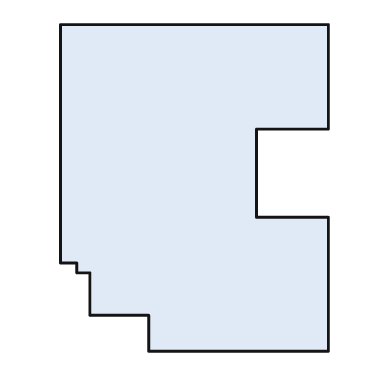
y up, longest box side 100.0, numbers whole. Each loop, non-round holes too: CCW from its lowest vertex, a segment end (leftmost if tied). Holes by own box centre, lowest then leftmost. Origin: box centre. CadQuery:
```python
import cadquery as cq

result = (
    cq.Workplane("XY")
    .moveTo(-14.0, -50.0)
    .lineTo(41.0, -50.0)
    .lineTo(41.0, -9.0)
    .lineTo(19.0, -9.0)
    .lineTo(19.0, 18.0)
    .lineTo(41.0, 18.0)
    .lineTo(41.0, 50.0)
    .lineTo(-41.0, 50.0)
    .lineTo(-41.0, -23.0)
    .lineTo(-36.0, -23.0)
    .lineTo(-36.0, -26.0)
    .lineTo(-32.0, -26.0)
    .lineTo(-32.0, -39.0)
    .lineTo(-14.0, -39.0)
    .close()
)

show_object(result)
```